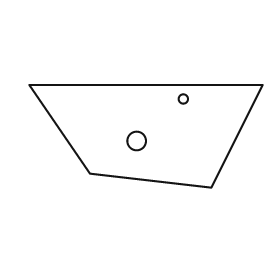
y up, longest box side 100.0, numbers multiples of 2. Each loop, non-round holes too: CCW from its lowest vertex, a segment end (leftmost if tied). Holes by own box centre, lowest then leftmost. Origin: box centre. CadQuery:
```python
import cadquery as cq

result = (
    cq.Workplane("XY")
    .moveTo(28.0, -22.0)
    .lineTo(50.0, 22.0)
    .lineTo(-50.0, 22.0)
    .lineTo(-24.0, -16.0)
    .close()
    .moveTo(-4.0, -2.0)
    .circle(4.0)
    .moveTo(16.0, 16.0)
    .circle(2.0)
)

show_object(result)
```